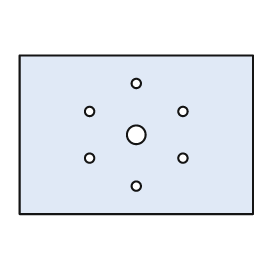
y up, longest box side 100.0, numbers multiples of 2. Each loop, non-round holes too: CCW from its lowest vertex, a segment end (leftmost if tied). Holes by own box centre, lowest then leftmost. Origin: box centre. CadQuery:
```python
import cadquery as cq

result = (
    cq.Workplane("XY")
    .moveTo(-50.0, -34.0)
    .lineTo(50.0, -34.0)
    .lineTo(50.0, 34.0)
    .lineTo(-50.0, 34.0)
    .close()
    .moveTo(0.0, -22.0)
    .circle(2.0)
    .moveTo(-20.0, -10.0)
    .circle(2.0)
    .moveTo(20.0, -10.0)
    .circle(2.0)
    .moveTo(0.0, 0.0)
    .circle(4.0)
    .moveTo(-20.0, 10.0)
    .circle(2.0)
    .moveTo(20.0, 10.0)
    .circle(2.0)
    .moveTo(0.0, 22.0)
    .circle(2.0)
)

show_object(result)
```